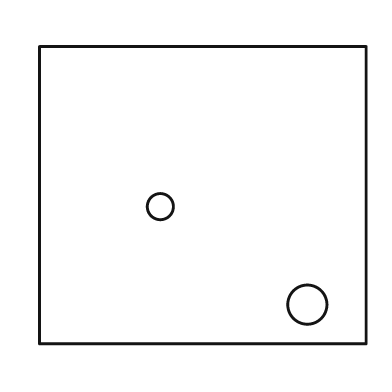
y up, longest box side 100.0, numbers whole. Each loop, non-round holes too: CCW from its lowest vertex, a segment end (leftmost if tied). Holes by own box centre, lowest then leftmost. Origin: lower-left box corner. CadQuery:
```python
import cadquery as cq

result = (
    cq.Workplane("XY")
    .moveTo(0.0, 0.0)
    .lineTo(100.0, 0.0)
    .lineTo(100.0, 91.0)
    .lineTo(0.0, 91.0)
    .close()
    .moveTo(82.0, 12.0)
    .circle(6.0)
    .moveTo(37.0, 42.0)
    .circle(4.0)
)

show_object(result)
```